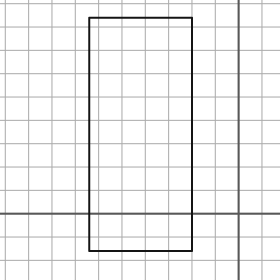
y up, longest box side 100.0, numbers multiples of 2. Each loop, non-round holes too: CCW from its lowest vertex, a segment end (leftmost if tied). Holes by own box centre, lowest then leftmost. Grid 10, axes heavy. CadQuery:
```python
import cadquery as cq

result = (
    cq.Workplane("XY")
    .moveTo(-64.0, -16.0)
    .lineTo(-20.0, -16.0)
    .lineTo(-20.0, 84.0)
    .lineTo(-64.0, 84.0)
    .close()
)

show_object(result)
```